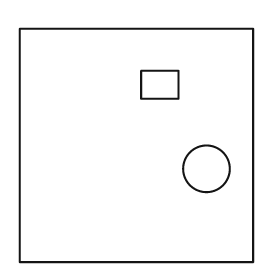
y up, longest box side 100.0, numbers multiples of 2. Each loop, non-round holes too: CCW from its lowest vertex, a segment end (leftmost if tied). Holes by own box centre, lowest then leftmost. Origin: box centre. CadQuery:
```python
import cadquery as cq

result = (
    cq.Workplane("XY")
    .moveTo(-50.0, -50.0)
    .lineTo(50.0, -50.0)
    .lineTo(50.0, 50.0)
    .lineTo(-50.0, 50.0)
    .close()
    .moveTo(30.0, -10.0)
    .circle(10.0)
    .moveTo(2.0, 20.0)
    .lineTo(18.0, 20.0)
    .lineTo(18.0, 32.0)
    .lineTo(2.0, 32.0)
    .close()
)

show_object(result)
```